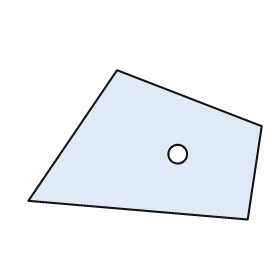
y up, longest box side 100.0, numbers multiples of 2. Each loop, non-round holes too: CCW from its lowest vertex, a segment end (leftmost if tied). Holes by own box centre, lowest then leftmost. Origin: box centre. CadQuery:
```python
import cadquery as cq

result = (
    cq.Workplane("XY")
    .moveTo(44.0, -32.0)
    .lineTo(50.0, 8.0)
    .lineTo(-12.0, 32.0)
    .lineTo(-50.0, -24.0)
    .close()
    .moveTo(14.0, -4.0)
    .circle(4.0)
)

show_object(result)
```